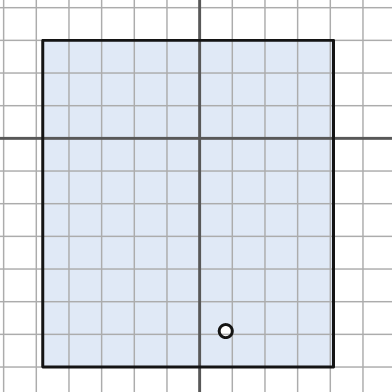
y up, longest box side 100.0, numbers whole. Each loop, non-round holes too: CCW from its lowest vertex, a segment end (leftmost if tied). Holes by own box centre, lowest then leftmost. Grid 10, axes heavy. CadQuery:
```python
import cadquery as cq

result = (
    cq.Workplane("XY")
    .moveTo(-48.0, -70.0)
    .lineTo(41.0, -70.0)
    .lineTo(41.0, 30.0)
    .lineTo(-48.0, 30.0)
    .close()
    .moveTo(8.0, -59.0)
    .circle(2.0)
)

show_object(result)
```